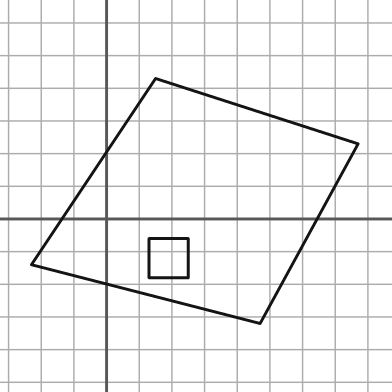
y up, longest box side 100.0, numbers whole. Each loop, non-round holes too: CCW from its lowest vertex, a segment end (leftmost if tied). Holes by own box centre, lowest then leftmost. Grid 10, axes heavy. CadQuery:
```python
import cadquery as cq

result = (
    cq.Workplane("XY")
    .moveTo(47.0, -32.0)
    .lineTo(77.0, 23.0)
    .lineTo(15.0, 43.0)
    .lineTo(-23.0, -14.0)
    .close()
    .moveTo(13.0, -18.0)
    .lineTo(25.0, -18.0)
    .lineTo(25.0, -6.0)
    .lineTo(13.0, -6.0)
    .close()
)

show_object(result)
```